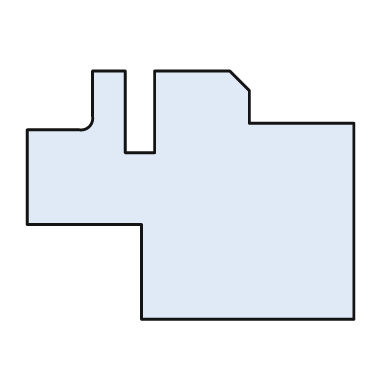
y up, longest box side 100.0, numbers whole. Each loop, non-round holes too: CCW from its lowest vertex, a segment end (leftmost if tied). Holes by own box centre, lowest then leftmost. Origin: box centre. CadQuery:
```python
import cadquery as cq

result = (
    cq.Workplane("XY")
    .moveTo(-15.0, -38.0)
    .lineTo(50.0, -38.0)
    .lineTo(50.0, 22.0)
    .lineTo(18.0, 22.0)
    .lineTo(18.0, 32.0)
    .lineTo(12.0, 38.0)
    .lineTo(-11.0, 38.0)
    .lineTo(-11.0, 13.0)
    .lineTo(-20.0, 13.0)
    .lineTo(-20.0, 38.0)
    .lineTo(-30.0, 38.0)
    .lineTo(-30.0, 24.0)
    .threePointArc((-31.0, 21.0), (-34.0, 20.0))
    .lineTo(-50.0, 20.0)
    .lineTo(-50.0, -9.0)
    .lineTo(-15.0, -9.0)
    .close()
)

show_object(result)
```